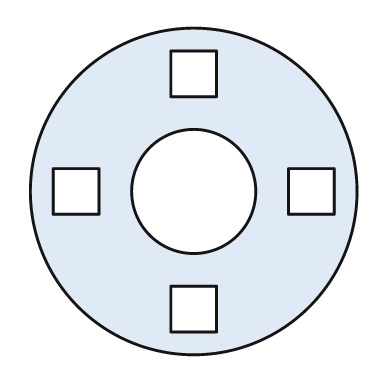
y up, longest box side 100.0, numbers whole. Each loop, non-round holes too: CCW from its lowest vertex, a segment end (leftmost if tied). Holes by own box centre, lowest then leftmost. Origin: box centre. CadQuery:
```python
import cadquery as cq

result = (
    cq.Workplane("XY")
    .moveTo(0.0, 0.0)
    .circle(50.0)
    .moveTo(-7.0, -43.0)
    .lineTo(7.0, -43.0)
    .lineTo(7.0, -29.0)
    .lineTo(-7.0, -29.0)
    .close()
    .moveTo(-43.0, -7.0)
    .lineTo(-29.0, -7.0)
    .lineTo(-29.0, 7.0)
    .lineTo(-43.0, 7.0)
    .close()
    .moveTo(0.0, 0.0)
    .circle(19.0)
    .moveTo(29.0, -7.0)
    .lineTo(43.0, -7.0)
    .lineTo(43.0, 7.0)
    .lineTo(29.0, 7.0)
    .close()
    .moveTo(-7.0, 29.0)
    .lineTo(7.0, 29.0)
    .lineTo(7.0, 43.0)
    .lineTo(-7.0, 43.0)
    .close()
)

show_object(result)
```